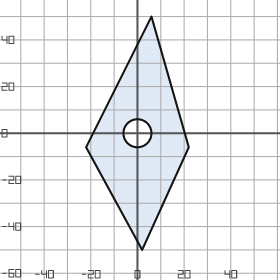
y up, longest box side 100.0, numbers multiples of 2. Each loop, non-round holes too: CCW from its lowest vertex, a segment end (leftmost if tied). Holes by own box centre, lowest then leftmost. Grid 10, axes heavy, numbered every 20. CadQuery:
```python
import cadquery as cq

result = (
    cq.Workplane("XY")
    .moveTo(2.0, -50.0)
    .lineTo(22.0, -6.0)
    .lineTo(6.0, 50.0)
    .lineTo(-22.0, -6.0)
    .close()
    .moveTo(0.0, 0.0)
    .circle(6.0)
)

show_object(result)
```